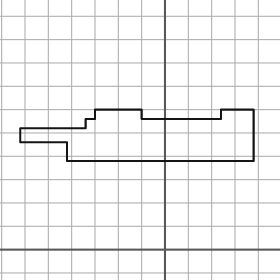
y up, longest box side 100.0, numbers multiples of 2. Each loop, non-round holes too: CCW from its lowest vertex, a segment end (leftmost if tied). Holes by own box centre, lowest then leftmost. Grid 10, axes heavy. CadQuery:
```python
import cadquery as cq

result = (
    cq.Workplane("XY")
    .moveTo(-42.0, 38.0)
    .lineTo(38.0, 38.0)
    .lineTo(38.0, 60.0)
    .lineTo(24.0, 60.0)
    .lineTo(24.0, 56.0)
    .lineTo(-10.0, 56.0)
    .lineTo(-10.0, 60.0)
    .lineTo(-30.0, 60.0)
    .lineTo(-30.0, 56.0)
    .lineTo(-34.0, 56.0)
    .lineTo(-34.0, 52.0)
    .lineTo(-62.0, 52.0)
    .lineTo(-62.0, 46.0)
    .lineTo(-42.0, 46.0)
    .close()
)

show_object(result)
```